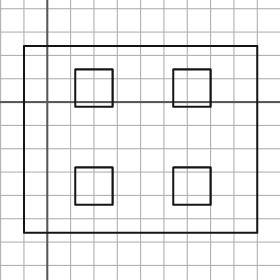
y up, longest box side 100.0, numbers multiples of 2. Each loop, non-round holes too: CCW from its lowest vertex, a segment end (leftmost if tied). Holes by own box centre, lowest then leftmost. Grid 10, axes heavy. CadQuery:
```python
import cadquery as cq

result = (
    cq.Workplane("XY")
    .moveTo(-10.0, -56.0)
    .lineTo(90.0, -56.0)
    .lineTo(90.0, 24.0)
    .lineTo(-10.0, 24.0)
    .close()
    .moveTo(12.0, -44.0)
    .lineTo(28.0, -44.0)
    .lineTo(28.0, -28.0)
    .lineTo(12.0, -28.0)
    .close()
    .moveTo(54.0, -44.0)
    .lineTo(70.0, -44.0)
    .lineTo(70.0, -28.0)
    .lineTo(54.0, -28.0)
    .close()
    .moveTo(12.0, -2.0)
    .lineTo(28.0, -2.0)
    .lineTo(28.0, 14.0)
    .lineTo(12.0, 14.0)
    .close()
    .moveTo(54.0, -2.0)
    .lineTo(70.0, -2.0)
    .lineTo(70.0, 14.0)
    .lineTo(54.0, 14.0)
    .close()
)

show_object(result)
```